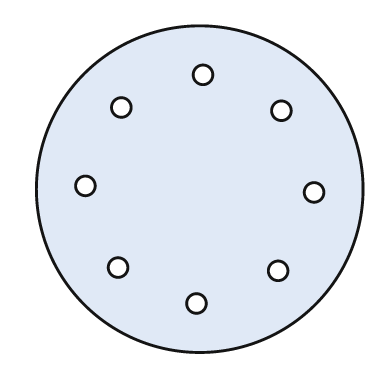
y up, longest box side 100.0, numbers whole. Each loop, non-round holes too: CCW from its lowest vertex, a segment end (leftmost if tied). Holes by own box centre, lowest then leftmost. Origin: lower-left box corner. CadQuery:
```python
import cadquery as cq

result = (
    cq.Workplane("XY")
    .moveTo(50.0, 50.0)
    .circle(50.0)
    .moveTo(49.0, 15.0)
    .circle(3.0)
    .moveTo(74.0, 25.0)
    .circle(3.0)
    .moveTo(25.0, 26.0)
    .circle(3.0)
    .moveTo(85.0, 49.0)
    .circle(3.0)
    .moveTo(15.0, 51.0)
    .circle(3.0)
    .moveTo(75.0, 74.0)
    .circle(3.0)
    .moveTo(26.0, 75.0)
    .circle(3.0)
    .moveTo(51.0, 85.0)
    .circle(3.0)
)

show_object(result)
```